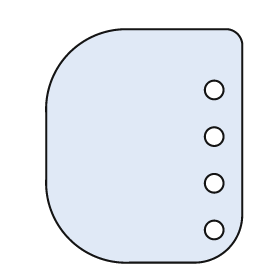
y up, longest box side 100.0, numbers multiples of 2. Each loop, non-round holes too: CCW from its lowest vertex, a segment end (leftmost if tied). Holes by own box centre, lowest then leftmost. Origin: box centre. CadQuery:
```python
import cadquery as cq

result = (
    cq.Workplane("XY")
    .moveTo(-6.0, -50.0)
    .lineTo(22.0, -50.0)
    .threePointArc((36.0, -44.0), (42.0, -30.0))
    .lineTo(42.0, 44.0)
    .threePointArc((40.0, 48.0), (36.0, 50.0))
    .lineTo(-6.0, 50.0)
    .threePointArc((-32.0, 40.0), (-42.0, 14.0))
    .lineTo(-42.0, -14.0)
    .threePointArc((-32.0, -40.0), (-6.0, -50.0))
    .close()
    .moveTo(30.0, -36.0)
    .circle(4.0)
    .moveTo(30.0, -16.0)
    .circle(4.0)
    .moveTo(30.0, 4.0)
    .circle(4.0)
    .moveTo(30.0, 24.0)
    .circle(4.0)
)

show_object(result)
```